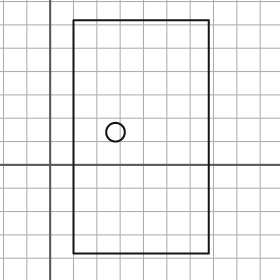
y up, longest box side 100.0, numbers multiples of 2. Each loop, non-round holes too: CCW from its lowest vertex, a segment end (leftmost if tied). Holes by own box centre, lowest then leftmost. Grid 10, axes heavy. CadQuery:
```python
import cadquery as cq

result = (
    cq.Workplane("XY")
    .moveTo(10.0, -38.0)
    .lineTo(68.0, -38.0)
    .lineTo(68.0, 62.0)
    .lineTo(10.0, 62.0)
    .close()
    .moveTo(28.0, 14.0)
    .circle(4.0)
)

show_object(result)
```